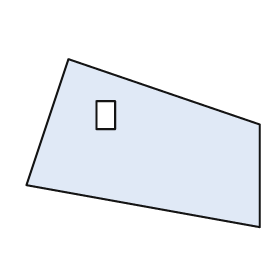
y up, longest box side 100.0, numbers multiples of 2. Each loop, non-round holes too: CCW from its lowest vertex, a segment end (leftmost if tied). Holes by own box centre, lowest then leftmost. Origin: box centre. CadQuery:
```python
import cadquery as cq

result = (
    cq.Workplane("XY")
    .moveTo(50.0, -36.0)
    .lineTo(50.0, 8.0)
    .lineTo(-32.0, 36.0)
    .lineTo(-50.0, -18.0)
    .close()
    .moveTo(-20.0, 6.0)
    .lineTo(-12.0, 6.0)
    .lineTo(-12.0, 18.0)
    .lineTo(-20.0, 18.0)
    .close()
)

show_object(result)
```